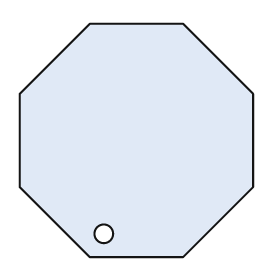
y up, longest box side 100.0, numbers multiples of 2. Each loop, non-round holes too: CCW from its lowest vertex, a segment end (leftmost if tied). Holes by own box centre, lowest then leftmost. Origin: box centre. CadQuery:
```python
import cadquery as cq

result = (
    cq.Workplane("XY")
    .moveTo(-20.0, -50.0)
    .lineTo(20.0, -50.0)
    .lineTo(50.0, -20.0)
    .lineTo(50.0, 20.0)
    .lineTo(20.0, 50.0)
    .lineTo(-20.0, 50.0)
    .lineTo(-50.0, 20.0)
    .lineTo(-50.0, -20.0)
    .close()
    .moveTo(-14.0, -40.0)
    .circle(4.0)
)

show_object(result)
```